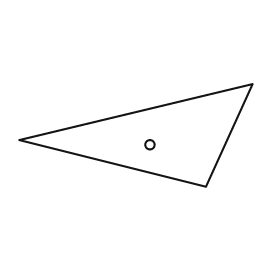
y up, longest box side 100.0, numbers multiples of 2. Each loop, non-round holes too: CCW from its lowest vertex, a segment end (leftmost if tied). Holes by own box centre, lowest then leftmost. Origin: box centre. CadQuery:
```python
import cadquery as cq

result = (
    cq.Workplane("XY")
    .moveTo(30.0, -22.0)
    .lineTo(50.0, 22.0)
    .lineTo(-50.0, -2.0)
    .close()
    .moveTo(6.0, -4.0)
    .circle(2.0)
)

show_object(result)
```